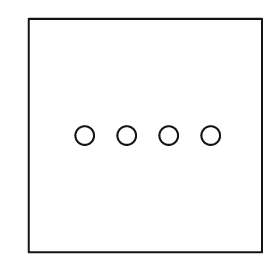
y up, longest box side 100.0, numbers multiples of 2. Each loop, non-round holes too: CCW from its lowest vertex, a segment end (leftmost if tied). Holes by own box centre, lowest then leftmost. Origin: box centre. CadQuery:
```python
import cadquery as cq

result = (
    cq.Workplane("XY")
    .moveTo(-50.0, -50.0)
    .lineTo(50.0, -50.0)
    .lineTo(50.0, 50.0)
    .lineTo(-50.0, 50.0)
    .close()
    .moveTo(-26.0, 0.0)
    .circle(4.0)
    .moveTo(-8.0, 0.0)
    .circle(4.0)
    .moveTo(10.0, 0.0)
    .circle(4.0)
    .moveTo(28.0, 0.0)
    .circle(4.0)
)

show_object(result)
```